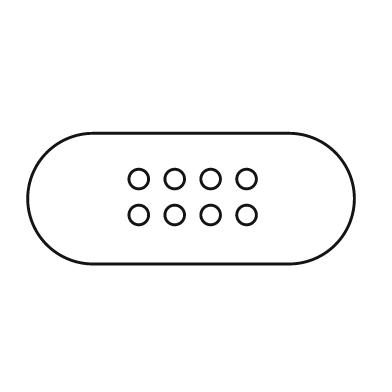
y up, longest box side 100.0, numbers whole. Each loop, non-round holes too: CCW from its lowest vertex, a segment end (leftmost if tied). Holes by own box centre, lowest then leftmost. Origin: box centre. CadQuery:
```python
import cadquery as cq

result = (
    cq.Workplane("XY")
    .moveTo(-30.0, -20.0)
    .lineTo(30.0, -20.0)
    .threePointArc((50.0, 0.0), (30.0, 20.0))
    .lineTo(-30.0, 20.0)
    .threePointArc((-50.0, 0.0), (-30.0, -20.0))
    .close()
    .moveTo(-16.0, -5.0)
    .circle(3.0)
    .moveTo(-5.0, -5.0)
    .circle(3.0)
    .moveTo(6.0, -5.0)
    .circle(3.0)
    .moveTo(17.0, -5.0)
    .circle(3.0)
    .moveTo(-16.0, 6.0)
    .circle(3.0)
    .moveTo(-5.0, 6.0)
    .circle(3.0)
    .moveTo(6.0, 6.0)
    .circle(3.0)
    .moveTo(17.0, 6.0)
    .circle(3.0)
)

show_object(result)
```